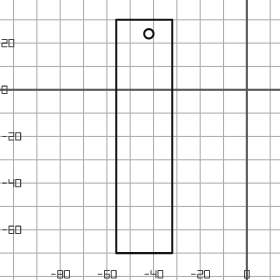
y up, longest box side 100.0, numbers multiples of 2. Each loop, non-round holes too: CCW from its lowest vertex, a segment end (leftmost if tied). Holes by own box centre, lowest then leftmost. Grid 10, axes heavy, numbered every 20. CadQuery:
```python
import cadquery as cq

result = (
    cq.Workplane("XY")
    .moveTo(-56.0, -70.0)
    .lineTo(-32.0, -70.0)
    .lineTo(-32.0, 30.0)
    .lineTo(-56.0, 30.0)
    .close()
    .moveTo(-42.0, 24.0)
    .circle(2.0)
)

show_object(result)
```